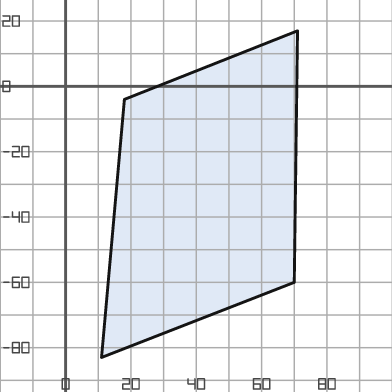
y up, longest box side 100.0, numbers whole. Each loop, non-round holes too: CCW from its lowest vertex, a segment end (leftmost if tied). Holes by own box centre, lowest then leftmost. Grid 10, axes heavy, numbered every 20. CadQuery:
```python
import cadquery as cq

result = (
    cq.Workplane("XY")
    .moveTo(11.0, -83.0)
    .lineTo(70.0, -60.0)
    .lineTo(71.0, 17.0)
    .lineTo(18.0, -4.0)
    .close()
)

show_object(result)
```